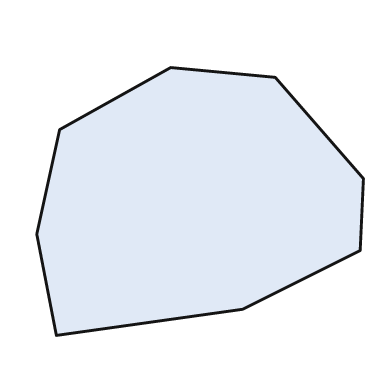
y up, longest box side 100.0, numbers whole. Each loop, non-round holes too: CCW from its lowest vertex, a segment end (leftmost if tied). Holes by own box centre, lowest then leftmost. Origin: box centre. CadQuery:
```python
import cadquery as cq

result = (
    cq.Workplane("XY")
    .moveTo(-44.0, -41.0)
    .lineTo(13.0, -33.0)
    .lineTo(49.0, -15.0)
    .lineTo(50.0, 7.0)
    .lineTo(23.0, 38.0)
    .lineTo(-9.0, 41.0)
    .lineTo(-43.0, 22.0)
    .lineTo(-50.0, -10.0)
    .close()
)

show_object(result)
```